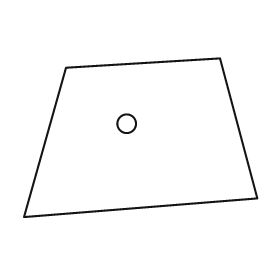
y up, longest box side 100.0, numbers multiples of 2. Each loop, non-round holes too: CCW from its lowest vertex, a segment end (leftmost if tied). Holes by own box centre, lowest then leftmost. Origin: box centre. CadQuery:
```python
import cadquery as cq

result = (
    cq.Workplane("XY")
    .moveTo(-50.0, -34.0)
    .lineTo(50.0, -26.0)
    .lineTo(34.0, 34.0)
    .lineTo(-32.0, 30.0)
    .close()
    .moveTo(-6.0, 6.0)
    .circle(4.0)
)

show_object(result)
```